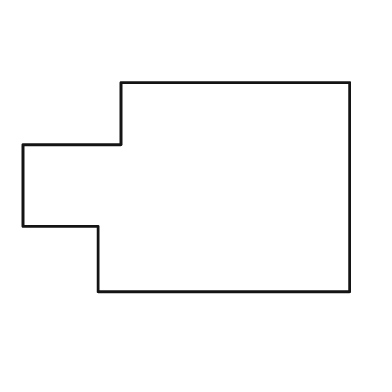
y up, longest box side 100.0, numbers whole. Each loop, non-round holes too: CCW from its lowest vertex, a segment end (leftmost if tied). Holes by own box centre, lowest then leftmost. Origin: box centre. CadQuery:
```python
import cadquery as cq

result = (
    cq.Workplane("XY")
    .moveTo(-27.0, -32.0)
    .lineTo(50.0, -32.0)
    .lineTo(50.0, 32.0)
    .lineTo(-20.0, 32.0)
    .lineTo(-20.0, 13.0)
    .lineTo(-50.0, 13.0)
    .lineTo(-50.0, -12.0)
    .lineTo(-27.0, -12.0)
    .close()
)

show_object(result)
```